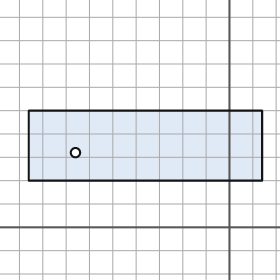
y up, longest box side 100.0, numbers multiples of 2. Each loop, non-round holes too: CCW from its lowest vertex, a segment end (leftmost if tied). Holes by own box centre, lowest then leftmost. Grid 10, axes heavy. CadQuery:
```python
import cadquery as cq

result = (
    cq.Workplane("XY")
    .moveTo(-86.0, 20.0)
    .lineTo(14.0, 20.0)
    .lineTo(14.0, 50.0)
    .lineTo(-86.0, 50.0)
    .close()
    .moveTo(-66.0, 32.0)
    .circle(2.0)
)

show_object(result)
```